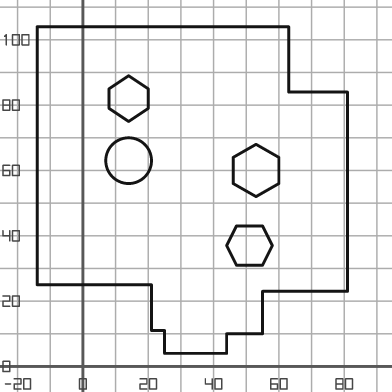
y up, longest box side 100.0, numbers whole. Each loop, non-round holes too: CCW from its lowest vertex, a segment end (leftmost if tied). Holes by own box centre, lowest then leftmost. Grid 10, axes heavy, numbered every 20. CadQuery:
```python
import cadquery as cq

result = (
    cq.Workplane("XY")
    .moveTo(25.0, 4.0)
    .lineTo(44.0, 4.0)
    .lineTo(44.0, 10.0)
    .lineTo(55.0, 10.0)
    .lineTo(55.0, 23.0)
    .lineTo(81.0, 23.0)
    .lineTo(81.0, 84.0)
    .lineTo(63.0, 84.0)
    .lineTo(63.0, 104.0)
    .lineTo(-14.0, 104.0)
    .lineTo(-14.0, 25.0)
    .lineTo(21.0, 25.0)
    .lineTo(21.0, 11.0)
    .lineTo(25.0, 11.0)
    .close()
    .moveTo(47.0, 31.0)
    .lineTo(55.0, 31.0)
    .lineTo(58.0, 37.0)
    .lineTo(55.0, 43.0)
    .lineTo(47.0, 43.0)
    .lineTo(44.0, 37.0)
    .close()
    .moveTo(53.0, 52.0)
    .lineTo(60.0, 56.0)
    .lineTo(60.0, 64.0)
    .lineTo(53.0, 68.0)
    .lineTo(46.0, 64.0)
    .lineTo(46.0, 56.0)
    .close()
    .moveTo(14.0, 63.0)
    .circle(7.0)
    .moveTo(14.0, 75.0)
    .lineTo(20.0, 79.0)
    .lineTo(20.0, 85.0)
    .lineTo(14.0, 89.0)
    .lineTo(8.0, 85.0)
    .lineTo(8.0, 79.0)
    .close()
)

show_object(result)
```